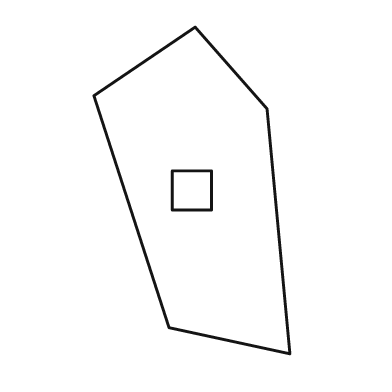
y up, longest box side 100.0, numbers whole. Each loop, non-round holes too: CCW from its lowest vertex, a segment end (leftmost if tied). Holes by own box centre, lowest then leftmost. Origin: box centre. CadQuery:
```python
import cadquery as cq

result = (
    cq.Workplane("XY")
    .moveTo(30.0, -50.0)
    .lineTo(23.0, 25.0)
    .lineTo(1.0, 50.0)
    .lineTo(-30.0, 29.0)
    .lineTo(-7.0, -42.0)
    .close()
    .moveTo(-6.0, -6.0)
    .lineTo(6.0, -6.0)
    .lineTo(6.0, 6.0)
    .lineTo(-6.0, 6.0)
    .close()
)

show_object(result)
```